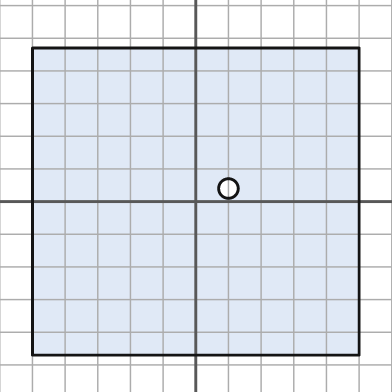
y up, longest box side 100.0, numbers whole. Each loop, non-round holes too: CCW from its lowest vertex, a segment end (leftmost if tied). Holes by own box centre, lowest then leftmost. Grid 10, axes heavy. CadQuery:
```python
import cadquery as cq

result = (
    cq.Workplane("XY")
    .moveTo(-50.0, -47.0)
    .lineTo(50.0, -47.0)
    .lineTo(50.0, 47.0)
    .lineTo(-50.0, 47.0)
    .close()
    .moveTo(10.0, 4.0)
    .circle(3.0)
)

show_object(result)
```